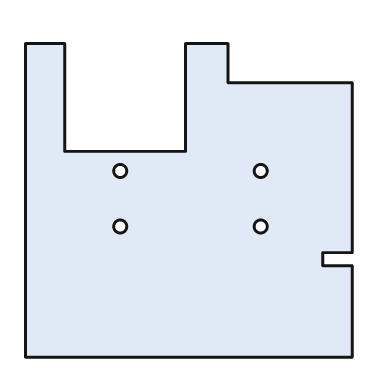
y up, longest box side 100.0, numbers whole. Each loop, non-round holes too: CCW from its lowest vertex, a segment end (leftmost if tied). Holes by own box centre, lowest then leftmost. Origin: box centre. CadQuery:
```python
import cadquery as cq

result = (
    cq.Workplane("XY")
    .moveTo(-50.0, -48.0)
    .lineTo(50.0, -48.0)
    .lineTo(50.0, -20.0)
    .lineTo(41.0, -20.0)
    .lineTo(41.0, -16.0)
    .lineTo(50.0, -16.0)
    .lineTo(50.0, 36.0)
    .lineTo(12.0, 36.0)
    .lineTo(12.0, 48.0)
    .lineTo(-1.0, 48.0)
    .lineTo(-1.0, 15.0)
    .lineTo(-38.0, 15.0)
    .lineTo(-38.0, 48.0)
    .lineTo(-50.0, 48.0)
    .close()
    .moveTo(-21.0, -8.0)
    .circle(2.0)
    .moveTo(22.0, -8.0)
    .circle(2.0)
    .moveTo(-21.0, 9.0)
    .circle(2.0)
    .moveTo(22.0, 9.0)
    .circle(2.0)
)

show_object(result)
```